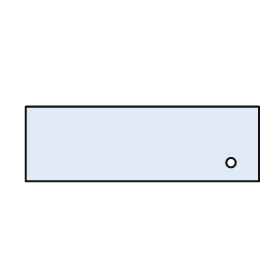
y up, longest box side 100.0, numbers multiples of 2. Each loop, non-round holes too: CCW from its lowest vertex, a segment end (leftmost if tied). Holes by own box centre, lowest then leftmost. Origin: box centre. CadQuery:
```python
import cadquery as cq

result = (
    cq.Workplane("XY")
    .moveTo(-50.0, -16.0)
    .lineTo(50.0, -16.0)
    .lineTo(50.0, 16.0)
    .lineTo(-50.0, 16.0)
    .close()
    .moveTo(38.0, -8.0)
    .circle(2.0)
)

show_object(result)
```